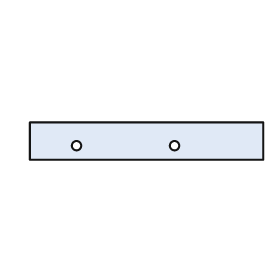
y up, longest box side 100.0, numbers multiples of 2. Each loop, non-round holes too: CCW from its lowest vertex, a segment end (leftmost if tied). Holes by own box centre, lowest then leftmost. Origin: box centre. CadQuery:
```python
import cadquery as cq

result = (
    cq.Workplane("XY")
    .moveTo(-50.0, -8.0)
    .lineTo(50.0, -8.0)
    .lineTo(50.0, 8.0)
    .lineTo(-50.0, 8.0)
    .close()
    .moveTo(-30.0, -2.0)
    .circle(2.0)
    .moveTo(12.0, -2.0)
    .circle(2.0)
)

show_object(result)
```